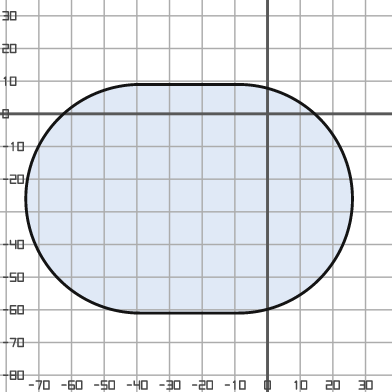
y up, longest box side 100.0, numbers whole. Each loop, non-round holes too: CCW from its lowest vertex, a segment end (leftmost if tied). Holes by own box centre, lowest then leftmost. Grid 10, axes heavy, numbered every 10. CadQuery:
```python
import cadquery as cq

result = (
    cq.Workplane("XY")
    .moveTo(-39.0, -61.0)
    .lineTo(-9.0, -61.0)
    .threePointArc((26.0, -26.0), (-9.0, 9.0))
    .lineTo(-39.0, 9.0)
    .threePointArc((-74.0, -26.0), (-39.0, -61.0))
    .close()
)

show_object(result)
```